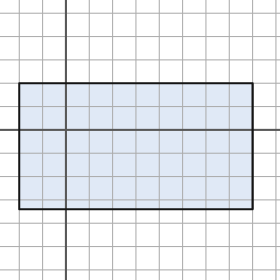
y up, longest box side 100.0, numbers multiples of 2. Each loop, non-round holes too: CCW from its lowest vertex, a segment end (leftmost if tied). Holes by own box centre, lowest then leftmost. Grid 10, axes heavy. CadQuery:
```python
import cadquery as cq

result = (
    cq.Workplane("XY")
    .moveTo(-20.0, -34.0)
    .lineTo(80.0, -34.0)
    .lineTo(80.0, 20.0)
    .lineTo(-20.0, 20.0)
    .close()
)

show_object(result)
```